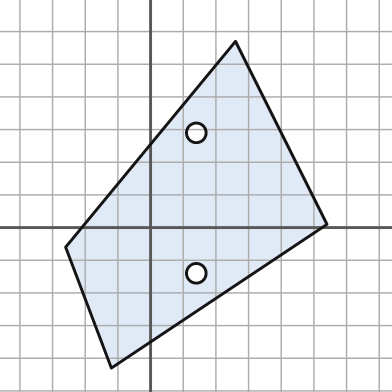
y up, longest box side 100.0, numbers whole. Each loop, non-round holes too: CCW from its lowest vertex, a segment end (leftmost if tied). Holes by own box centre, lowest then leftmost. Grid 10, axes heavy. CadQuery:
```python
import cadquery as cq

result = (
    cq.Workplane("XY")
    .moveTo(-12.0, -43.0)
    .lineTo(54.0, 1.0)
    .lineTo(26.0, 57.0)
    .lineTo(-26.0, -6.0)
    .close()
    .moveTo(14.0, -14.0)
    .circle(3.0)
    .moveTo(14.0, 29.0)
    .circle(3.0)
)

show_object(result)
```